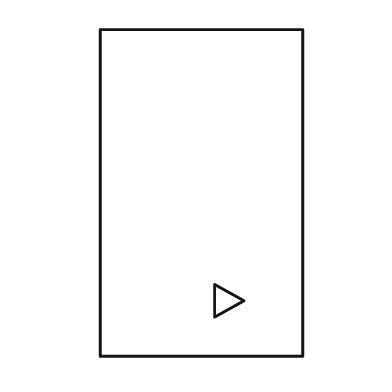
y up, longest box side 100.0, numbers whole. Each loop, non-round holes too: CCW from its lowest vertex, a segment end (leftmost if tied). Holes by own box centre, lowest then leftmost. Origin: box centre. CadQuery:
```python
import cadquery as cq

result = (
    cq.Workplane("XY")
    .moveTo(-31.0, -50.0)
    .lineTo(31.0, -50.0)
    .lineTo(31.0, 50.0)
    .lineTo(-31.0, 50.0)
    .close()
    .moveTo(4.0, -38.0)
    .lineTo(13.0, -33.0)
    .lineTo(4.0, -28.0)
    .close()
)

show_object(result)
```